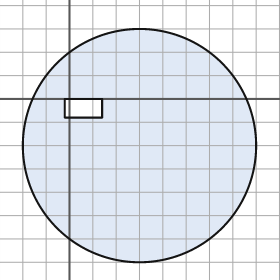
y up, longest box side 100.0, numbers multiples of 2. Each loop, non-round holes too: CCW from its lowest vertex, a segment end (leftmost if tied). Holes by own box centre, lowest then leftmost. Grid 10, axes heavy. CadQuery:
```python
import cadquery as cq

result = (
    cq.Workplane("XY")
    .moveTo(30.0, -20.0)
    .circle(50.0)
    .moveTo(-2.0, -8.0)
    .lineTo(14.0, -8.0)
    .lineTo(14.0, 0.0)
    .lineTo(-2.0, 0.0)
    .close()
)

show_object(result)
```